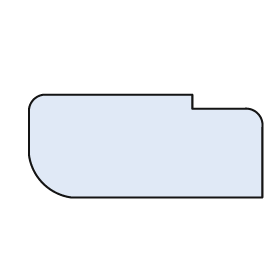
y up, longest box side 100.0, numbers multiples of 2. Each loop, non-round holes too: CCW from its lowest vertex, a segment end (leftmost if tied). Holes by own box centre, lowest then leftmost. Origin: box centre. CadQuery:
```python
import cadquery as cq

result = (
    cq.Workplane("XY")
    .moveTo(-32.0, -22.0)
    .lineTo(50.0, -22.0)
    .lineTo(50.0, 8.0)
    .threePointArc((48.0, 14.0), (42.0, 16.0))
    .lineTo(20.0, 16.0)
    .lineTo(20.0, 22.0)
    .lineTo(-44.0, 22.0)
    .threePointArc((-48.0, 20.0), (-50.0, 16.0))
    .lineTo(-50.0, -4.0)
    .threePointArc((-44.0, -16.0), (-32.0, -22.0))
    .close()
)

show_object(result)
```